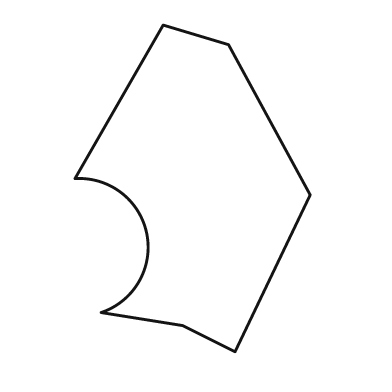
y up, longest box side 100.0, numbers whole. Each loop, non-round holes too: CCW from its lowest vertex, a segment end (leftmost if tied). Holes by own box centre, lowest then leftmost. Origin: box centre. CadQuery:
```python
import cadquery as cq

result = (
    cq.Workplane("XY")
    .moveTo(13.0, -50.0)
    .lineTo(36.0, -2.0)
    .lineTo(11.0, 44.0)
    .lineTo(-9.0, 50.0)
    .lineTo(-36.0, 3.0)
    .threePointArc((-14.0, -14.0), (-28.0, -38.0))
    .lineTo(-3.0, -42.0)
    .close()
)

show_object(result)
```